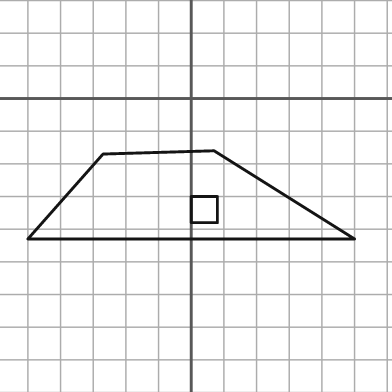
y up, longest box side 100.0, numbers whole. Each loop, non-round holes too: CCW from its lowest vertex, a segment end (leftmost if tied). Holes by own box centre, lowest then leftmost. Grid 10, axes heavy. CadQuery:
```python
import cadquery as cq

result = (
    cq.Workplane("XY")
    .moveTo(-50.0, -43.0)
    .lineTo(50.0, -43.0)
    .lineTo(7.0, -16.0)
    .lineTo(-27.0, -17.0)
    .close()
    .moveTo(0.0, -38.0)
    .lineTo(8.0, -38.0)
    .lineTo(8.0, -30.0)
    .lineTo(0.0, -30.0)
    .close()
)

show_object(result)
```